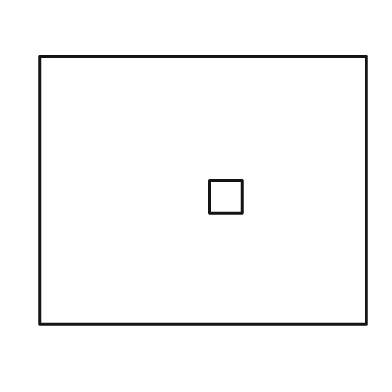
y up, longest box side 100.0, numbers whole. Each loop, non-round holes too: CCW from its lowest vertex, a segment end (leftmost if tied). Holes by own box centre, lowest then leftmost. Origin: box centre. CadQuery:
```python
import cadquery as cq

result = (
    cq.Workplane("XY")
    .moveTo(-50.0, -41.0)
    .lineTo(50.0, -41.0)
    .lineTo(50.0, 41.0)
    .lineTo(-50.0, 41.0)
    .close()
    .moveTo(2.0, -7.0)
    .lineTo(12.0, -7.0)
    .lineTo(12.0, 3.0)
    .lineTo(2.0, 3.0)
    .close()
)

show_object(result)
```